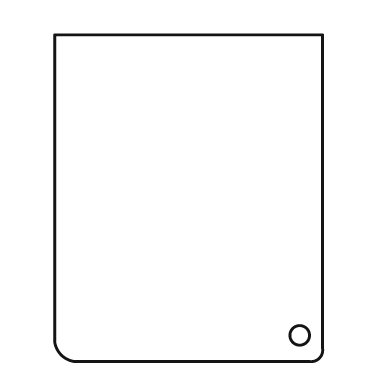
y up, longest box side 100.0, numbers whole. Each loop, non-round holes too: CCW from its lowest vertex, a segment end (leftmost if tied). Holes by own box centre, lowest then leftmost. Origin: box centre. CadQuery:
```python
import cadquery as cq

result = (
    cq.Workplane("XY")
    .moveTo(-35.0, -50.0)
    .lineTo(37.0, -50.0)
    .threePointArc((40.0, -49.0), (41.0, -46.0))
    .lineTo(41.0, 50.0)
    .lineTo(-41.0, 50.0)
    .lineTo(-41.0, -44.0)
    .threePointArc((-39.0, -48.0), (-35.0, -50.0))
    .close()
    .moveTo(34.0, -42.0)
    .circle(3.0)
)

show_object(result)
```